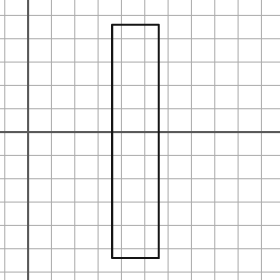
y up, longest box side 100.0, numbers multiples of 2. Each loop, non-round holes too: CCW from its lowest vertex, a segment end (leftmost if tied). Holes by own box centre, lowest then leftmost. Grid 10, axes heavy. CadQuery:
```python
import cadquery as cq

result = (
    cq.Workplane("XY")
    .moveTo(36.0, -54.0)
    .lineTo(56.0, -54.0)
    .lineTo(56.0, 46.0)
    .lineTo(36.0, 46.0)
    .close()
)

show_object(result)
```